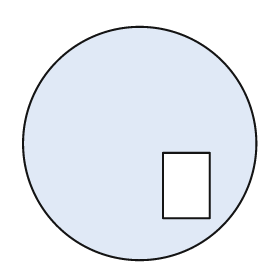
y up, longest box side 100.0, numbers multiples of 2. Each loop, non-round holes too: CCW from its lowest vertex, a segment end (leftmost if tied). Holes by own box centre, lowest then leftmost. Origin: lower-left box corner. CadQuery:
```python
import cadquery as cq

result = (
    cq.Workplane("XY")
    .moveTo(50.0, 50.0)
    .circle(50.0)
    .moveTo(60.0, 18.0)
    .lineTo(80.0, 18.0)
    .lineTo(80.0, 46.0)
    .lineTo(60.0, 46.0)
    .close()
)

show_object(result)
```